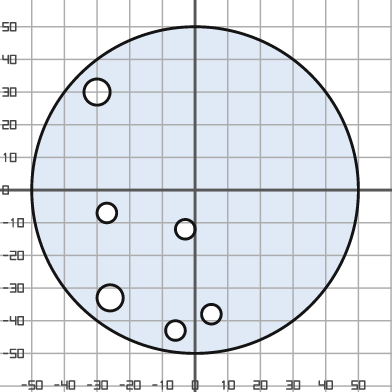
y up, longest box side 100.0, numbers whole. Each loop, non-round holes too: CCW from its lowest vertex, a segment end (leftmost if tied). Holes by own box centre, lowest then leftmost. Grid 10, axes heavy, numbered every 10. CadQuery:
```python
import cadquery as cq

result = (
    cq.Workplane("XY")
    .moveTo(0.0, 0.0)
    .circle(50.0)
    .moveTo(-6.0, -43.0)
    .circle(3.0)
    .moveTo(5.0, -38.0)
    .circle(3.0)
    .moveTo(-26.0, -33.0)
    .circle(4.0)
    .moveTo(-3.0, -12.0)
    .circle(3.0)
    .moveTo(-27.0, -7.0)
    .circle(3.0)
    .moveTo(-30.0, 30.0)
    .circle(4.0)
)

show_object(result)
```